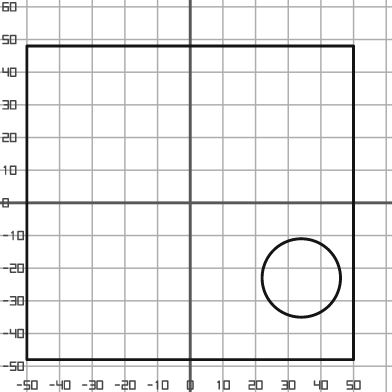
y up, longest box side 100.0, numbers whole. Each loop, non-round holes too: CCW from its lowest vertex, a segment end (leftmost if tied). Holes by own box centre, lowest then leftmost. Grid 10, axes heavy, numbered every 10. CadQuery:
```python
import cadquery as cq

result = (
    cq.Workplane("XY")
    .moveTo(-50.0, -48.0)
    .lineTo(50.0, -48.0)
    .lineTo(50.0, 48.0)
    .lineTo(-50.0, 48.0)
    .close()
    .moveTo(34.0, -23.0)
    .circle(12.0)
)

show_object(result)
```